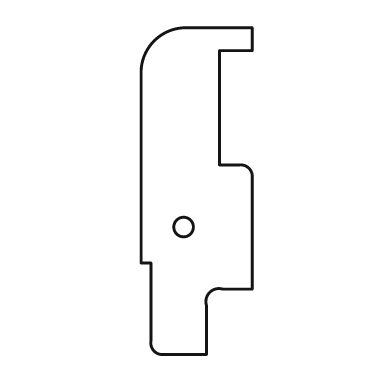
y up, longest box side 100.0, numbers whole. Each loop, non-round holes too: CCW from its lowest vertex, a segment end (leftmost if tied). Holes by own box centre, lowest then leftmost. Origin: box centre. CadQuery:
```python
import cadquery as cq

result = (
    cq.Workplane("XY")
    .moveTo(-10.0, -50.0)
    .lineTo(3.0, -50.0)
    .lineTo(3.0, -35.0)
    .threePointArc((4.0, -31.0), (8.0, -30.0))
    .lineTo(17.0, -30.0)
    .lineTo(17.0, 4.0)
    .threePointArc((16.0, 7.0), (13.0, 8.0))
    .lineTo(7.0, 8.0)
    .lineTo(7.0, 43.0)
    .lineTo(17.0, 43.0)
    .lineTo(17.0, 50.0)
    .lineTo(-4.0, 50.0)
    .threePointArc((-13.0, 46.0), (-17.0, 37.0))
    .lineTo(-17.0, -22.0)
    .lineTo(-14.0, -22.0)
    .lineTo(-14.0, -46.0)
    .threePointArc((-13.0, -49.0), (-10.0, -50.0))
    .close()
    .moveTo(-4.0, -11.0)
    .circle(3.0)
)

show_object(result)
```